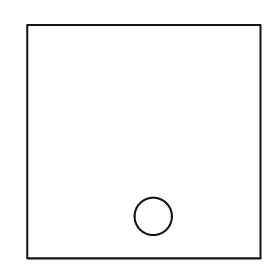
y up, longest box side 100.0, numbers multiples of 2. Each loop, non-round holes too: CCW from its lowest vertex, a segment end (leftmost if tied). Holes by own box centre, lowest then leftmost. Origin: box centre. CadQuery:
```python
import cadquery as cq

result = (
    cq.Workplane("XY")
    .moveTo(-50.0, -50.0)
    .lineTo(50.0, -50.0)
    .lineTo(50.0, 50.0)
    .lineTo(-50.0, 50.0)
    .close()
    .moveTo(4.0, -32.0)
    .circle(8.0)
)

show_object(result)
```